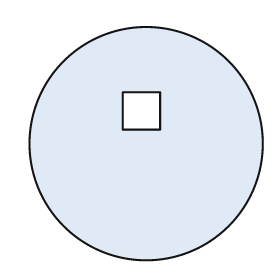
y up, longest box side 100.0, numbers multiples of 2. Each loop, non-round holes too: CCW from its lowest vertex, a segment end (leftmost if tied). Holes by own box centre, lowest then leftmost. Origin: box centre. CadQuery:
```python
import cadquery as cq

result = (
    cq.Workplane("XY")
    .moveTo(0.0, 0.0)
    .circle(50.0)
    .moveTo(-10.0, 6.0)
    .lineTo(6.0, 6.0)
    .lineTo(6.0, 22.0)
    .lineTo(-10.0, 22.0)
    .close()
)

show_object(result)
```